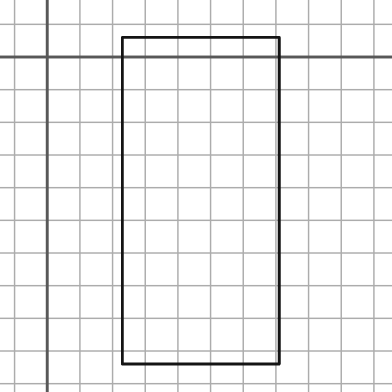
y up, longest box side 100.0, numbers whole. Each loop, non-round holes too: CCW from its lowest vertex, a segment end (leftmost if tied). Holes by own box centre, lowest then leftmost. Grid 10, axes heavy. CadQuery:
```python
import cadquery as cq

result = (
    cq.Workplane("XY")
    .moveTo(23.0, -94.0)
    .lineTo(71.0, -94.0)
    .lineTo(71.0, 6.0)
    .lineTo(23.0, 6.0)
    .close()
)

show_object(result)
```